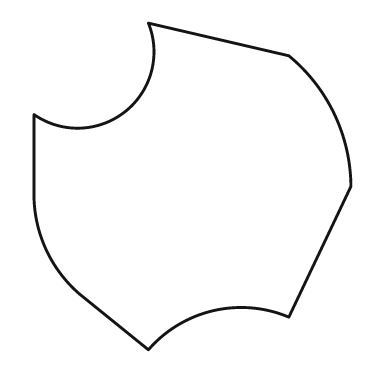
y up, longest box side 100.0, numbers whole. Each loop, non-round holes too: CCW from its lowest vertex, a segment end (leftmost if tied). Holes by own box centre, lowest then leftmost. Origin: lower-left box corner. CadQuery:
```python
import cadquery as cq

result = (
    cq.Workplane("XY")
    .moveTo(35.0, 0.0)
    .threePointArc((55.0, 12.0), (78.0, 10.0))
    .lineTo(97.0, 50.0)
    .threePointArc((92.0, 72.0), (78.0, 90.0))
    .lineTo(35.0, 100.0)
    .threePointArc((28.0, 73.0), (0.0, 72.0))
    .lineTo(0.0, 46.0)
    .threePointArc((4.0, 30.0), (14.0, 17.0))
    .close()
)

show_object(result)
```